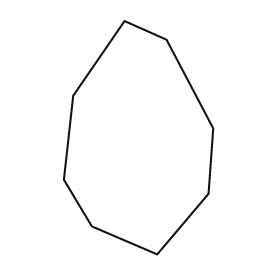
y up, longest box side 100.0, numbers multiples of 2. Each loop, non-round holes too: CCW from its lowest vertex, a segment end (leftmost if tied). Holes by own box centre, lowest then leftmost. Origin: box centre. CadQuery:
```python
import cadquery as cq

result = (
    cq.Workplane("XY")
    .moveTo(8.0, -50.0)
    .lineTo(30.0, -24.0)
    .lineTo(32.0, 4.0)
    .lineTo(12.0, 42.0)
    .lineTo(-6.0, 50.0)
    .lineTo(-28.0, 18.0)
    .lineTo(-32.0, -18.0)
    .lineTo(-20.0, -38.0)
    .close()
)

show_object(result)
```